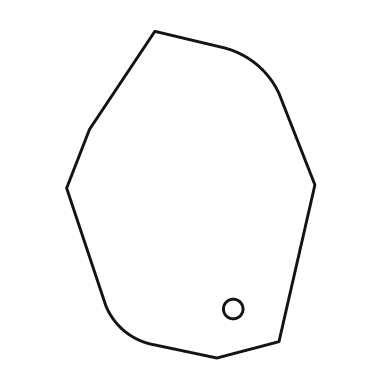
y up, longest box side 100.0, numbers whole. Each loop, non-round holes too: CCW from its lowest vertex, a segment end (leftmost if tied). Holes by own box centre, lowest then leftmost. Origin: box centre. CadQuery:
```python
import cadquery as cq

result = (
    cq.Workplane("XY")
    .moveTo(8.0, -50.0)
    .lineTo(27.0, -45.0)
    .lineTo(38.0, 3.0)
    .lineTo(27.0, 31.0)
    .threePointArc((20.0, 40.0), (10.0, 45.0))
    .lineTo(-11.0, 50.0)
    .lineTo(-31.0, 20.0)
    .lineTo(-38.0, 2.0)
    .lineTo(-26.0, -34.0)
    .threePointArc((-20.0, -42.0), (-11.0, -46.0))
    .close()
    .moveTo(13.0, -35.0)
    .circle(3.0)
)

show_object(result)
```